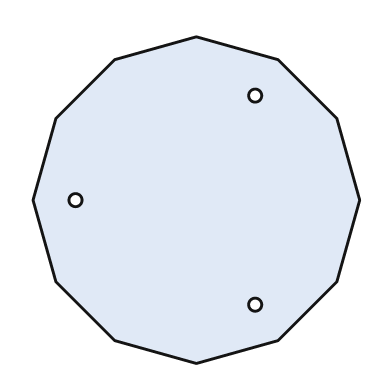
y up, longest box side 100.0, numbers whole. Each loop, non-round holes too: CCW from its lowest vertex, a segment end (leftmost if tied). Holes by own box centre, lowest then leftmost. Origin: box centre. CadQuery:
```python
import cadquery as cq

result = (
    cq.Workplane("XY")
    .moveTo(0.0, -50.0)
    .lineTo(25.0, -43.0)
    .lineTo(43.0, -25.0)
    .lineTo(50.0, 0.0)
    .lineTo(43.0, 25.0)
    .lineTo(25.0, 43.0)
    .lineTo(0.0, 50.0)
    .lineTo(-25.0, 43.0)
    .lineTo(-43.0, 25.0)
    .lineTo(-50.0, 0.0)
    .lineTo(-43.0, -25.0)
    .lineTo(-25.0, -43.0)
    .close()
    .moveTo(18.0, -32.0)
    .circle(2.0)
    .moveTo(-37.0, 0.0)
    .circle(2.0)
    .moveTo(18.0, 32.0)
    .circle(2.0)
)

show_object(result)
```